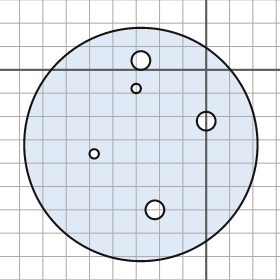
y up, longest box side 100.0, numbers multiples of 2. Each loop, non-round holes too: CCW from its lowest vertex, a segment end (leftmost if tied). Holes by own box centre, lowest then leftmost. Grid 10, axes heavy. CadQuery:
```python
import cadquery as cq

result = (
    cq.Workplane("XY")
    .moveTo(-28.0, -32.0)
    .circle(50.0)
    .moveTo(-22.0, -60.0)
    .circle(4.0)
    .moveTo(-48.0, -36.0)
    .circle(2.0)
    .moveTo(0.0, -22.0)
    .circle(4.0)
    .moveTo(-30.0, -8.0)
    .circle(2.0)
    .moveTo(-28.0, 4.0)
    .circle(4.0)
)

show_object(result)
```